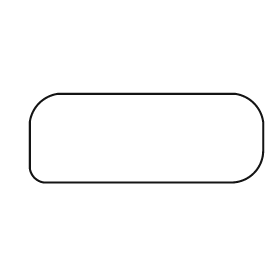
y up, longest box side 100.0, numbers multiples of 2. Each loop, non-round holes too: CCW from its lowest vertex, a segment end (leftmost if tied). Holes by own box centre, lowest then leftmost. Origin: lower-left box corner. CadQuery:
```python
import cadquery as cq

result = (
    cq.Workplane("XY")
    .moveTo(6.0, 0.0)
    .lineTo(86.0, 0.0)
    .threePointArc((96.0, 4.0), (100.0, 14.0))
    .lineTo(100.0, 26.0)
    .threePointArc((96.0, 34.0), (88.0, 38.0))
    .lineTo(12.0, 38.0)
    .threePointArc((4.0, 34.0), (0.0, 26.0))
    .lineTo(0.0, 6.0)
    .threePointArc((2.0, 2.0), (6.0, 0.0))
    .close()
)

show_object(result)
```